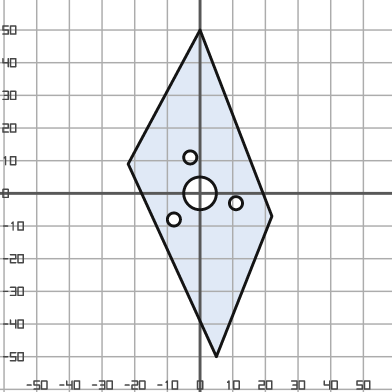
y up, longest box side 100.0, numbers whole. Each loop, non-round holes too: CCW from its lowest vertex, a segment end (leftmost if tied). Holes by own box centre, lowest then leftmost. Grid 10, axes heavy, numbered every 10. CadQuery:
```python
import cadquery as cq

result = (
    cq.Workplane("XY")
    .moveTo(5.0, -50.0)
    .lineTo(22.0, -7.0)
    .lineTo(0.0, 50.0)
    .lineTo(-22.0, 9.0)
    .close()
    .moveTo(-8.0, -8.0)
    .circle(2.0)
    .moveTo(11.0, -3.0)
    .circle(2.0)
    .moveTo(0.0, 0.0)
    .circle(5.0)
    .moveTo(-3.0, 11.0)
    .circle(2.0)
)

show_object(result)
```